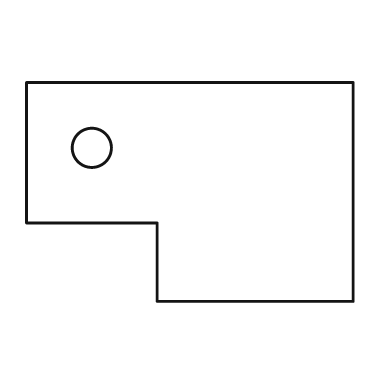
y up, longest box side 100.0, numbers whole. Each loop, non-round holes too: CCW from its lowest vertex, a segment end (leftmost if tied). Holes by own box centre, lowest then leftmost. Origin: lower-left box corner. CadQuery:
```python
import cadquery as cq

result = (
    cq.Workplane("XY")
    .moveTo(40.0, 0.0)
    .lineTo(100.0, 0.0)
    .lineTo(100.0, 67.0)
    .lineTo(0.0, 67.0)
    .lineTo(0.0, 24.0)
    .lineTo(40.0, 24.0)
    .close()
    .moveTo(20.0, 47.0)
    .circle(6.0)
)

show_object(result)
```